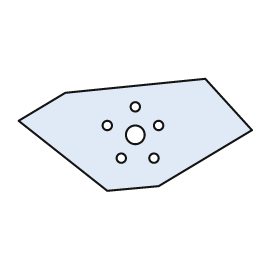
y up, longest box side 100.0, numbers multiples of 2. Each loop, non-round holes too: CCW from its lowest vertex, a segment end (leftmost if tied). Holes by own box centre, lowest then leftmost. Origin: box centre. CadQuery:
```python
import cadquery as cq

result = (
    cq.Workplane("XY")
    .moveTo(-12.0, -24.0)
    .lineTo(10.0, -22.0)
    .lineTo(50.0, 2.0)
    .lineTo(30.0, 24.0)
    .lineTo(-30.0, 18.0)
    .lineTo(-50.0, 6.0)
    .close()
    .moveTo(-6.0, -10.0)
    .circle(2.0)
    .moveTo(8.0, -10.0)
    .circle(2.0)
    .moveTo(0.0, 0.0)
    .circle(4.0)
    .moveTo(-12.0, 4.0)
    .circle(2.0)
    .moveTo(10.0, 4.0)
    .circle(2.0)
    .moveTo(0.0, 12.0)
    .circle(2.0)
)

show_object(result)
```